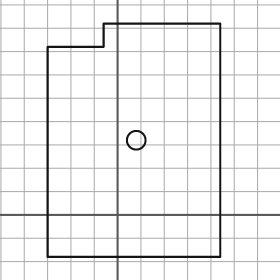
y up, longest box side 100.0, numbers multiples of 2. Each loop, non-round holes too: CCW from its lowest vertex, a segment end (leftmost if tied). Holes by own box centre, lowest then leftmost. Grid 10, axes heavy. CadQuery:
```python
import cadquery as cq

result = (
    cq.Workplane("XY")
    .moveTo(-30.0, -18.0)
    .lineTo(44.0, -18.0)
    .lineTo(44.0, 82.0)
    .lineTo(-6.0, 82.0)
    .lineTo(-6.0, 72.0)
    .lineTo(-30.0, 72.0)
    .close()
    .moveTo(8.0, 32.0)
    .circle(4.0)
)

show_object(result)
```